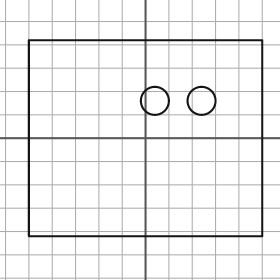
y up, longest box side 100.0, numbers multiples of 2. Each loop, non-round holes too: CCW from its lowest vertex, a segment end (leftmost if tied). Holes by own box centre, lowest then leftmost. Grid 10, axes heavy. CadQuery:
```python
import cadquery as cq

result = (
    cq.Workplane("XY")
    .moveTo(-50.0, -42.0)
    .lineTo(50.0, -42.0)
    .lineTo(50.0, 42.0)
    .lineTo(-50.0, 42.0)
    .close()
    .moveTo(4.0, 16.0)
    .circle(6.0)
    .moveTo(24.0, 16.0)
    .circle(6.0)
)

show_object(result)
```